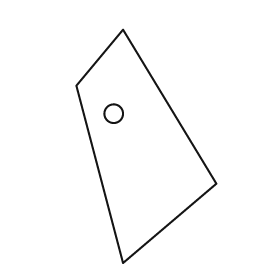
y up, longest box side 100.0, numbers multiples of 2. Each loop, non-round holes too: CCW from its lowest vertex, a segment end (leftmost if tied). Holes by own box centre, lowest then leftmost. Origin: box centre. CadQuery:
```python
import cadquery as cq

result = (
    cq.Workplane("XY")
    .moveTo(-10.0, -50.0)
    .lineTo(30.0, -16.0)
    .lineTo(-10.0, 50.0)
    .lineTo(-30.0, 26.0)
    .close()
    .moveTo(-14.0, 14.0)
    .circle(4.0)
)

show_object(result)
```